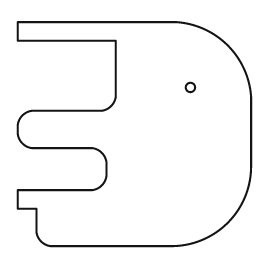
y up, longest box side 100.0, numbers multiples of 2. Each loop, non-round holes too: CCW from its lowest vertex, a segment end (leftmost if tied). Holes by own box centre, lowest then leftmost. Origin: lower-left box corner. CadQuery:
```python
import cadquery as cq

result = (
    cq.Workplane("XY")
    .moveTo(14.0, 0.0)
    .lineTo(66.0, 0.0)
    .threePointArc((90.0, 10.0), (100.0, 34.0))
    .lineTo(100.0, 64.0)
    .threePointArc((90.0, 86.0), (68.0, 96.0))
    .lineTo(0.0, 96.0)
    .lineTo(0.0, 88.0)
    .lineTo(42.0, 88.0)
    .lineTo(42.0, 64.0)
    .threePointArc((40.0, 60.0), (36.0, 58.0))
    .lineTo(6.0, 58.0)
    .threePointArc((2.0, 56.0), (0.0, 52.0))
    .lineTo(0.0, 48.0)
    .threePointArc((2.0, 44.0), (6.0, 42.0))
    .lineTo(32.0, 42.0)
    .threePointArc((36.0, 40.0), (38.0, 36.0))
    .lineTo(38.0, 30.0)
    .threePointArc((36.0, 26.0), (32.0, 24.0))
    .lineTo(0.0, 24.0)
    .lineTo(0.0, 16.0)
    .lineTo(8.0, 16.0)
    .lineTo(8.0, 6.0)
    .threePointArc((10.0, 2.0), (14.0, 0.0))
    .close()
    .moveTo(74.0, 68.0)
    .circle(2.0)
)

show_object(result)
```